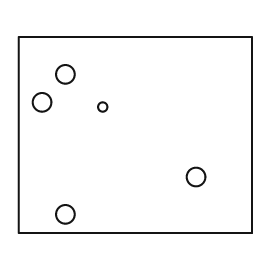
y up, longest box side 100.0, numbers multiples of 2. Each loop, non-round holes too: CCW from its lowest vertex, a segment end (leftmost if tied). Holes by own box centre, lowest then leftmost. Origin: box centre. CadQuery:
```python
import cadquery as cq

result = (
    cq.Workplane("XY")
    .moveTo(-50.0, -42.0)
    .lineTo(50.0, -42.0)
    .lineTo(50.0, 42.0)
    .lineTo(-50.0, 42.0)
    .close()
    .moveTo(-30.0, -34.0)
    .circle(4.0)
    .moveTo(26.0, -18.0)
    .circle(4.0)
    .moveTo(-14.0, 12.0)
    .circle(2.0)
    .moveTo(-40.0, 14.0)
    .circle(4.0)
    .moveTo(-30.0, 26.0)
    .circle(4.0)
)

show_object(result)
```